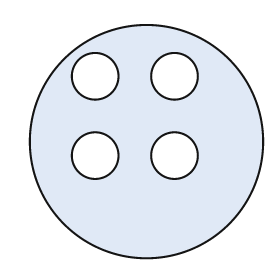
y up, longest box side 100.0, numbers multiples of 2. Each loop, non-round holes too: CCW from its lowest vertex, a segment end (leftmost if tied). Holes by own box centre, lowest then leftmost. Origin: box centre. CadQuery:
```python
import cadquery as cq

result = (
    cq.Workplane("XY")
    .moveTo(0.0, 0.0)
    .circle(50.0)
    .moveTo(-22.0, -6.0)
    .circle(10.0)
    .moveTo(12.0, -6.0)
    .circle(10.0)
    .moveTo(-22.0, 28.0)
    .circle(10.0)
    .moveTo(12.0, 28.0)
    .circle(10.0)
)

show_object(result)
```